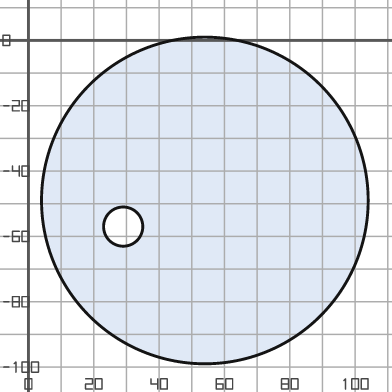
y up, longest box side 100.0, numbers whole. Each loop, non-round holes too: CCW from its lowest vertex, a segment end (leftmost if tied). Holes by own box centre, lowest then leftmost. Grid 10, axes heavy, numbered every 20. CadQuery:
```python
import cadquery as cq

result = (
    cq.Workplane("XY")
    .moveTo(54.0, -49.0)
    .circle(50.0)
    .moveTo(29.0, -57.0)
    .circle(6.0)
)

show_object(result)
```